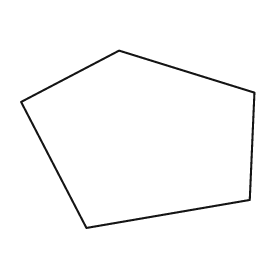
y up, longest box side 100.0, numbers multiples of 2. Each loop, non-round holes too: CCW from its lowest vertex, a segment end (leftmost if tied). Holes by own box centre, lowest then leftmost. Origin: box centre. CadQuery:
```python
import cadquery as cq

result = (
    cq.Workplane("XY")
    .moveTo(-22.0, -38.0)
    .lineTo(48.0, -26.0)
    .lineTo(50.0, 20.0)
    .lineTo(-8.0, 38.0)
    .lineTo(-50.0, 16.0)
    .close()
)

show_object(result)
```